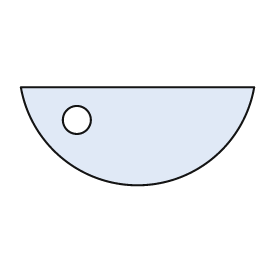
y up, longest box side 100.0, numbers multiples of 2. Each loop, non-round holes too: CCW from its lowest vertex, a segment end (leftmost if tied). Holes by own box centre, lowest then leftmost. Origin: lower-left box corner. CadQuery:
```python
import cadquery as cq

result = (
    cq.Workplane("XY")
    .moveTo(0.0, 42.0)
    .threePointArc((50.0, 0.0), (100.0, 42.0))
    .close()
    .moveTo(24.0, 28.0)
    .circle(6.0)
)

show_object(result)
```